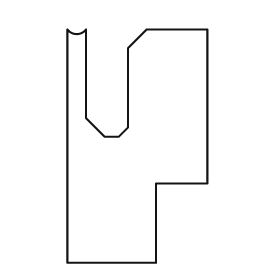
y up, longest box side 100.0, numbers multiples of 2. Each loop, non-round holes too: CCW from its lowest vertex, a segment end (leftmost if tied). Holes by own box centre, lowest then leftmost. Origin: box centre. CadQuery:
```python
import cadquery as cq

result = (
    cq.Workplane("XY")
    .moveTo(-30.0, -50.0)
    .lineTo(8.0, -50.0)
    .lineTo(8.0, -16.0)
    .lineTo(30.0, -16.0)
    .lineTo(30.0, 50.0)
    .lineTo(4.0, 50.0)
    .lineTo(-4.0, 42.0)
    .lineTo(-4.0, 8.0)
    .lineTo(-8.0, 4.0)
    .lineTo(-14.0, 4.0)
    .lineTo(-22.0, 12.0)
    .lineTo(-22.0, 50.0)
    .threePointArc((-26.0, 48.0), (-30.0, 50.0))
    .close()
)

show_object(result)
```